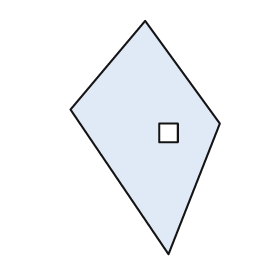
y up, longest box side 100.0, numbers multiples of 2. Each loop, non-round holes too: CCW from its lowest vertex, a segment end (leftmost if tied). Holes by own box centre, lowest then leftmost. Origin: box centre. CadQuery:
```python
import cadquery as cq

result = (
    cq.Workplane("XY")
    .moveTo(10.0, -50.0)
    .lineTo(32.0, 6.0)
    .lineTo(0.0, 50.0)
    .lineTo(-32.0, 12.0)
    .close()
    .moveTo(6.0, -2.0)
    .lineTo(14.0, -2.0)
    .lineTo(14.0, 6.0)
    .lineTo(6.0, 6.0)
    .close()
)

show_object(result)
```